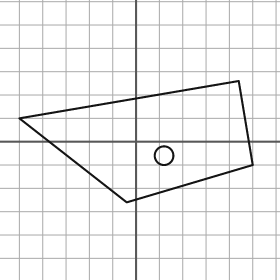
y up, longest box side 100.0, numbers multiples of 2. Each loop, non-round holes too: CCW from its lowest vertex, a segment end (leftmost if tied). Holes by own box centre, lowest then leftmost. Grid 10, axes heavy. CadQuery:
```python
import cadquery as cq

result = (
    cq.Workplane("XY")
    .moveTo(-4.0, -26.0)
    .lineTo(50.0, -10.0)
    .lineTo(44.0, 26.0)
    .lineTo(-50.0, 10.0)
    .close()
    .moveTo(12.0, -6.0)
    .circle(4.0)
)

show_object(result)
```